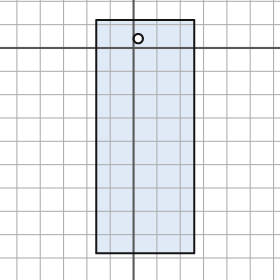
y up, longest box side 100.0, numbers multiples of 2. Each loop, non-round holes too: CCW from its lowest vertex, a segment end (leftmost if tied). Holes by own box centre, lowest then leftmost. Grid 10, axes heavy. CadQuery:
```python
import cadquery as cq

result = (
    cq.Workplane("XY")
    .moveTo(-16.0, -88.0)
    .lineTo(26.0, -88.0)
    .lineTo(26.0, 12.0)
    .lineTo(-16.0, 12.0)
    .close()
    .moveTo(2.0, 4.0)
    .circle(2.0)
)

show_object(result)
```